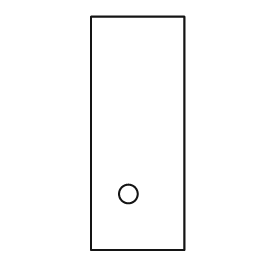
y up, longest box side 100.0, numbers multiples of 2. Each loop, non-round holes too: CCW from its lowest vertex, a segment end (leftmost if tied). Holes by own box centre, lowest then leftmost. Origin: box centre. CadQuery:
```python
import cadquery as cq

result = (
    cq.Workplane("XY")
    .moveTo(-20.0, -50.0)
    .lineTo(20.0, -50.0)
    .lineTo(20.0, 50.0)
    .lineTo(-20.0, 50.0)
    .close()
    .moveTo(-4.0, -26.0)
    .circle(4.0)
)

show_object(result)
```